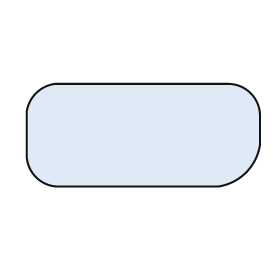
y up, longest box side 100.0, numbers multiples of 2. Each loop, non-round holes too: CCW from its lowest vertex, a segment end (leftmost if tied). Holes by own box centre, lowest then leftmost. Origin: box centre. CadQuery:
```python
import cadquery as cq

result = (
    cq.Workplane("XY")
    .moveTo(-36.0, -22.0)
    .lineTo(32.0, -22.0)
    .threePointArc((44.0, -16.0), (50.0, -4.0))
    .lineTo(50.0, 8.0)
    .threePointArc((46.0, 18.0), (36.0, 22.0))
    .lineTo(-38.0, 22.0)
    .threePointArc((-46.0, 18.0), (-50.0, 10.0))
    .lineTo(-50.0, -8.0)
    .threePointArc((-46.0, -18.0), (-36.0, -22.0))
    .close()
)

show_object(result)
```